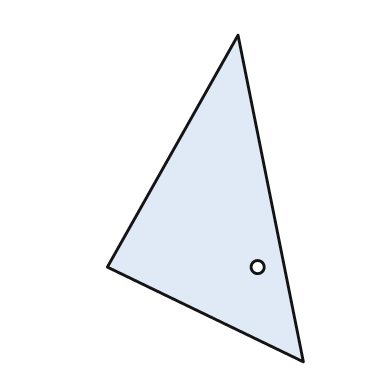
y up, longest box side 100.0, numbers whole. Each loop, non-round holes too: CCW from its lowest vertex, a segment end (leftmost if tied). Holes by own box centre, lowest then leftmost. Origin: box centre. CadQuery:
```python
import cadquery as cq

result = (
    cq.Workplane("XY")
    .moveTo(30.0, -50.0)
    .lineTo(10.0, 50.0)
    .lineTo(-30.0, -21.0)
    .close()
    .moveTo(16.0, -21.0)
    .circle(2.0)
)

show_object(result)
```